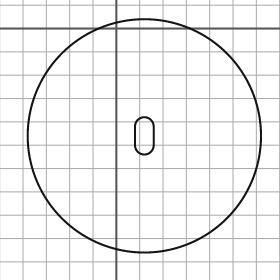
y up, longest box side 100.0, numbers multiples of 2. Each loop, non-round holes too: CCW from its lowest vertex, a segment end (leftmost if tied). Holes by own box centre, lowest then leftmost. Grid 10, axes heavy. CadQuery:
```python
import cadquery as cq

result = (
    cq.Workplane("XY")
    .moveTo(12.0, -46.0)
    .circle(50.0)
    .moveTo(8.0, -50.0)
    .threePointArc((12.0, -54.0), (16.0, -50.0))
    .lineTo(16.0, -42.0)
    .threePointArc((12.0, -38.0), (8.0, -42.0))
    .close()
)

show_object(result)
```